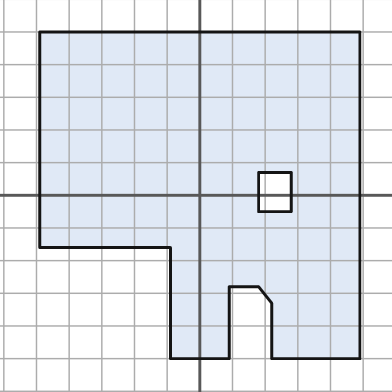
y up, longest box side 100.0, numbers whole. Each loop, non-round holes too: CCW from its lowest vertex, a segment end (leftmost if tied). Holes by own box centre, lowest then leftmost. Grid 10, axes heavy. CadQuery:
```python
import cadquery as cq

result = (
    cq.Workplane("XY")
    .moveTo(-9.0, -50.0)
    .lineTo(9.0, -50.0)
    .lineTo(9.0, -28.0)
    .lineTo(18.0, -28.0)
    .lineTo(22.0, -33.0)
    .lineTo(22.0, -50.0)
    .lineTo(49.0, -50.0)
    .lineTo(49.0, 50.0)
    .lineTo(-49.0, 50.0)
    .lineTo(-49.0, -16.0)
    .lineTo(-9.0, -16.0)
    .close()
    .moveTo(18.0, -5.0)
    .lineTo(28.0, -5.0)
    .lineTo(28.0, 7.0)
    .lineTo(18.0, 7.0)
    .close()
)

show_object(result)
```